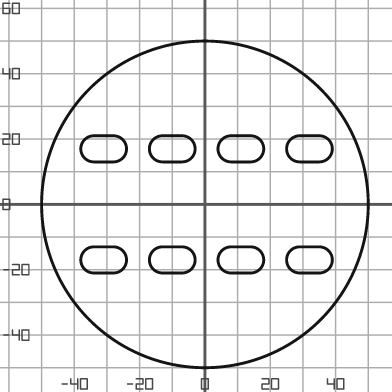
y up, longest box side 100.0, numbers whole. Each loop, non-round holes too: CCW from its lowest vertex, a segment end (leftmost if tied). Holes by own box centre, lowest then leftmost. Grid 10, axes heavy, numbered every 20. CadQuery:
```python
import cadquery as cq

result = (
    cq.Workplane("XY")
    .moveTo(0.0, 0.0)
    .circle(50.0)
    .moveTo(-34.0, -21.0)
    .lineTo(-28.0, -21.0)
    .threePointArc((-24.0, -17.0), (-28.0, -13.0))
    .lineTo(-34.0, -13.0)
    .threePointArc((-38.0, -17.0), (-34.0, -21.0))
    .close()
    .moveTo(-13.0, -21.0)
    .lineTo(-7.0, -21.0)
    .threePointArc((-3.0, -17.0), (-7.0, -13.0))
    .lineTo(-13.0, -13.0)
    .threePointArc((-17.0, -17.0), (-13.0, -21.0))
    .close()
    .moveTo(8.0, -21.0)
    .lineTo(14.0, -21.0)
    .threePointArc((18.0, -17.0), (14.0, -13.0))
    .lineTo(8.0, -13.0)
    .threePointArc((4.0, -17.0), (8.0, -21.0))
    .close()
    .moveTo(29.0, -21.0)
    .lineTo(35.0, -21.0)
    .threePointArc((39.0, -17.0), (35.0, -13.0))
    .lineTo(29.0, -13.0)
    .threePointArc((25.0, -17.0), (29.0, -21.0))
    .close()
    .moveTo(-34.0, 13.0)
    .lineTo(-28.0, 13.0)
    .threePointArc((-24.0, 17.0), (-28.0, 21.0))
    .lineTo(-34.0, 21.0)
    .threePointArc((-38.0, 17.0), (-34.0, 13.0))
    .close()
    .moveTo(-13.0, 13.0)
    .lineTo(-7.0, 13.0)
    .threePointArc((-3.0, 17.0), (-7.0, 21.0))
    .lineTo(-13.0, 21.0)
    .threePointArc((-17.0, 17.0), (-13.0, 13.0))
    .close()
    .moveTo(8.0, 13.0)
    .lineTo(14.0, 13.0)
    .threePointArc((18.0, 17.0), (14.0, 21.0))
    .lineTo(8.0, 21.0)
    .threePointArc((4.0, 17.0), (8.0, 13.0))
    .close()
    .moveTo(29.0, 13.0)
    .lineTo(35.0, 13.0)
    .threePointArc((39.0, 17.0), (35.0, 21.0))
    .lineTo(29.0, 21.0)
    .threePointArc((25.0, 17.0), (29.0, 13.0))
    .close()
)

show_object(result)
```